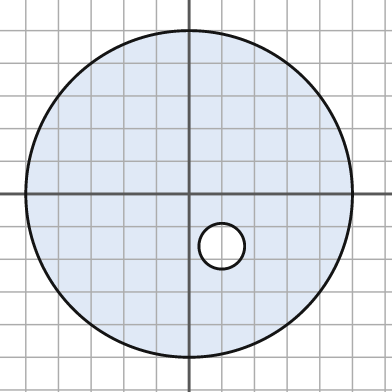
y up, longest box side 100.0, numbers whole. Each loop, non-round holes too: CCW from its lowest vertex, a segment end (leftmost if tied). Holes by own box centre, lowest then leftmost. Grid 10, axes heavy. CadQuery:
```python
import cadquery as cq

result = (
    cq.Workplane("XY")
    .moveTo(0.0, 0.0)
    .circle(50.0)
    .moveTo(10.0, -16.0)
    .circle(7.0)
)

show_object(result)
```